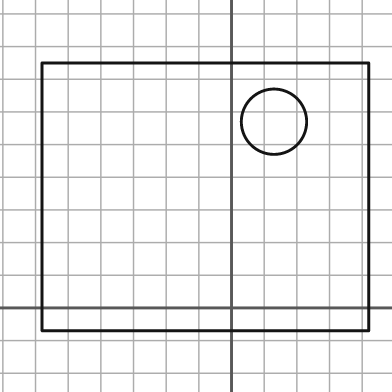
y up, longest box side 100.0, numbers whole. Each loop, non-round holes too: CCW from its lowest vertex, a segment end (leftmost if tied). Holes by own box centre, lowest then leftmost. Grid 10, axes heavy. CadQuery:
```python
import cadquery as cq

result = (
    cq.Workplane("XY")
    .moveTo(-58.0, -7.0)
    .lineTo(42.0, -7.0)
    .lineTo(42.0, 75.0)
    .lineTo(-58.0, 75.0)
    .close()
    .moveTo(13.0, 57.0)
    .circle(10.0)
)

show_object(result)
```